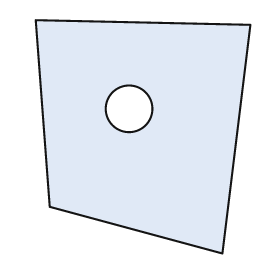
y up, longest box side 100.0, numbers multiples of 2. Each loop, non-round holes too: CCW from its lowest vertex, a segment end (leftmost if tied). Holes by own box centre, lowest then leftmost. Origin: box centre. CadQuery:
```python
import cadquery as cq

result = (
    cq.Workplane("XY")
    .moveTo(34.0, -50.0)
    .lineTo(46.0, 48.0)
    .lineTo(-46.0, 50.0)
    .lineTo(-40.0, -30.0)
    .close()
    .moveTo(-6.0, 12.0)
    .circle(10.0)
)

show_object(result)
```